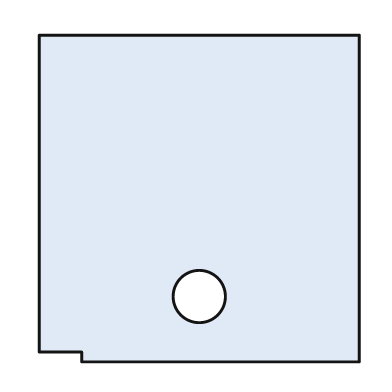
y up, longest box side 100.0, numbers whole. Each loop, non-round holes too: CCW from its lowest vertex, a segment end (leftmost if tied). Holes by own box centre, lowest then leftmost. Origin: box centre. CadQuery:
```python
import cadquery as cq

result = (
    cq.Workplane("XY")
    .moveTo(-36.0, -50.0)
    .lineTo(49.0, -50.0)
    .lineTo(49.0, 50.0)
    .lineTo(-49.0, 50.0)
    .lineTo(-49.0, -47.0)
    .lineTo(-36.0, -47.0)
    .close()
    .moveTo(0.0, -30.0)
    .circle(8.0)
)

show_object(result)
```